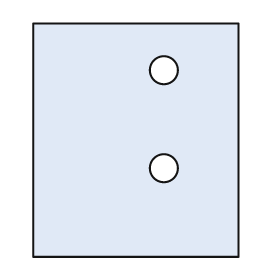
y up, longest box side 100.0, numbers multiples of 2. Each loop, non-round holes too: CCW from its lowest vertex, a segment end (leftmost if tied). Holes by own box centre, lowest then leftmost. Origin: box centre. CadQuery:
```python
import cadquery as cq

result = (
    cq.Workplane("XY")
    .moveTo(-44.0, -50.0)
    .lineTo(44.0, -50.0)
    .lineTo(44.0, 50.0)
    .lineTo(-44.0, 50.0)
    .close()
    .moveTo(12.0, -12.0)
    .circle(6.0)
    .moveTo(12.0, 30.0)
    .circle(6.0)
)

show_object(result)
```